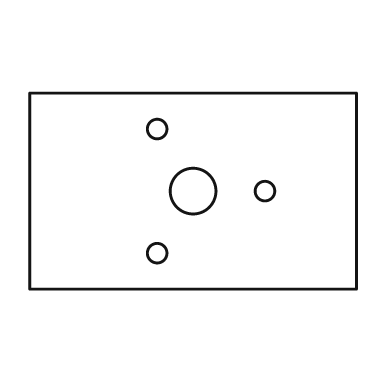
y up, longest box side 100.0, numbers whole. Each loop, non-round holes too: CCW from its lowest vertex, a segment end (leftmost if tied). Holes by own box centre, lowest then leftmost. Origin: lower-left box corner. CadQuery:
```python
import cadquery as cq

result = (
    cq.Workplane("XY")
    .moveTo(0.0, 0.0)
    .lineTo(100.0, 0.0)
    .lineTo(100.0, 60.0)
    .lineTo(0.0, 60.0)
    .close()
    .moveTo(39.0, 11.0)
    .circle(3.0)
    .moveTo(50.0, 30.0)
    .circle(7.0)
    .moveTo(72.0, 30.0)
    .circle(3.0)
    .moveTo(39.0, 49.0)
    .circle(3.0)
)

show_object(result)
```